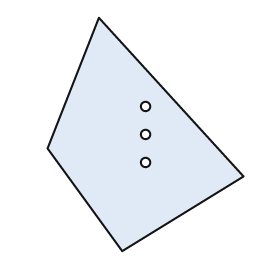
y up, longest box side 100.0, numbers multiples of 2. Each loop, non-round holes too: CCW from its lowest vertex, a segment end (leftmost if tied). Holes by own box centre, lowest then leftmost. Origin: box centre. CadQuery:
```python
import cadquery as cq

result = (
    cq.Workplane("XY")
    .moveTo(-10.0, -50.0)
    .lineTo(42.0, -18.0)
    .lineTo(-20.0, 50.0)
    .lineTo(-42.0, -6.0)
    .close()
    .moveTo(0.0, -12.0)
    .circle(2.0)
    .moveTo(0.0, 0.0)
    .circle(2.0)
    .moveTo(0.0, 12.0)
    .circle(2.0)
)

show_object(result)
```